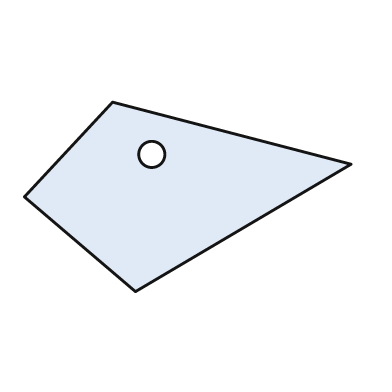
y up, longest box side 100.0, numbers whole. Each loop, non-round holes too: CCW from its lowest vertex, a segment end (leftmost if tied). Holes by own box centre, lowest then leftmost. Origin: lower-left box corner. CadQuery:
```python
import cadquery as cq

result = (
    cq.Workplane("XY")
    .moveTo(34.0, 0.0)
    .lineTo(100.0, 39.0)
    .lineTo(27.0, 58.0)
    .lineTo(0.0, 29.0)
    .close()
    .moveTo(39.0, 42.0)
    .circle(4.0)
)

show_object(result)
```